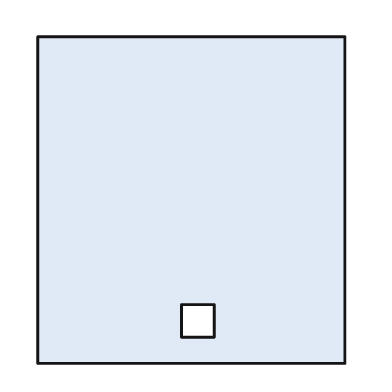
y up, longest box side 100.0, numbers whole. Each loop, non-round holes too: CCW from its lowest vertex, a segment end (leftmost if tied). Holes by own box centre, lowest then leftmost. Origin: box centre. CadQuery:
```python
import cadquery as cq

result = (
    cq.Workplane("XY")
    .moveTo(-47.0, -50.0)
    .lineTo(47.0, -50.0)
    .lineTo(47.0, 50.0)
    .lineTo(-47.0, 50.0)
    .close()
    .moveTo(-3.0, -42.0)
    .lineTo(7.0, -42.0)
    .lineTo(7.0, -32.0)
    .lineTo(-3.0, -32.0)
    .close()
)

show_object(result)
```